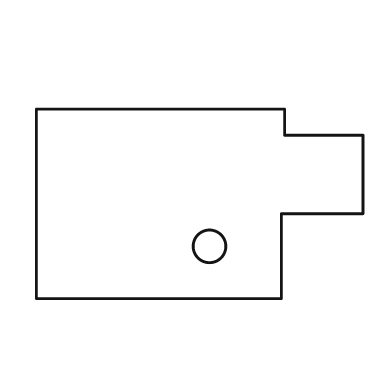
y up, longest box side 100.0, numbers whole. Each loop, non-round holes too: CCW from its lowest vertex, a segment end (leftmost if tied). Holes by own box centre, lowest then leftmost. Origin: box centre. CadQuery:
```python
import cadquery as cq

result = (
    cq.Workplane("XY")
    .moveTo(-50.0, -29.0)
    .lineTo(25.0, -29.0)
    .lineTo(25.0, -3.0)
    .lineTo(50.0, -3.0)
    .lineTo(50.0, 21.0)
    .lineTo(26.0, 21.0)
    .lineTo(26.0, 29.0)
    .lineTo(-50.0, 29.0)
    .close()
    .moveTo(3.0, -13.0)
    .circle(5.0)
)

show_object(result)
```